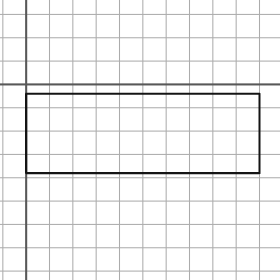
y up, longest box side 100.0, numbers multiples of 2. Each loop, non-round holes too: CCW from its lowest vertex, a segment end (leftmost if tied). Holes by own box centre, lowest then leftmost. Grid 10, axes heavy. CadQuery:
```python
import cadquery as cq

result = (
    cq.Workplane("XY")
    .moveTo(0.0, -38.0)
    .lineTo(100.0, -38.0)
    .lineTo(100.0, -4.0)
    .lineTo(0.0, -4.0)
    .close()
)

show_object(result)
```